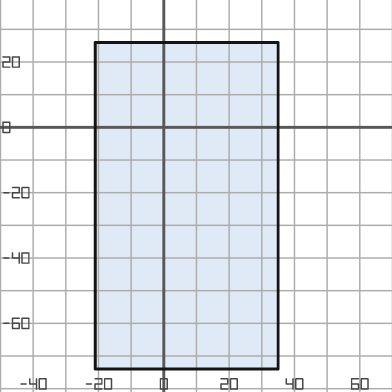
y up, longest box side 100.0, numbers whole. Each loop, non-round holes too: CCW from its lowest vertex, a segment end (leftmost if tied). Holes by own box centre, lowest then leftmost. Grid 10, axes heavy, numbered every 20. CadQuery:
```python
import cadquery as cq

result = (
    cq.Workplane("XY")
    .moveTo(-21.0, -74.0)
    .lineTo(35.0, -74.0)
    .lineTo(35.0, 26.0)
    .lineTo(-21.0, 26.0)
    .close()
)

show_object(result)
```